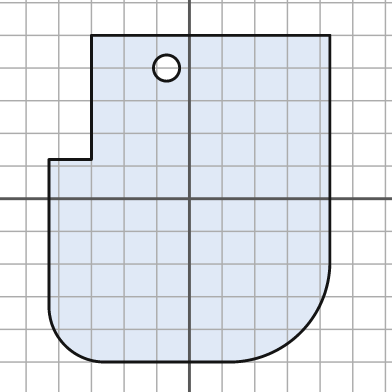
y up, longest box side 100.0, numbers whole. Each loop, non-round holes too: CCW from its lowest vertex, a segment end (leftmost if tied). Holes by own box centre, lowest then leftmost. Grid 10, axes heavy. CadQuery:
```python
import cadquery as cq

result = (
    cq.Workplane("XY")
    .moveTo(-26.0, -50.0)
    .lineTo(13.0, -50.0)
    .threePointArc((34.0, -41.0), (43.0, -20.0))
    .lineTo(43.0, 50.0)
    .lineTo(-30.0, 50.0)
    .lineTo(-30.0, 12.0)
    .lineTo(-43.0, 12.0)
    .lineTo(-43.0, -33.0)
    .threePointArc((-38.0, -45.0), (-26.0, -50.0))
    .close()
    .moveTo(-7.0, 40.0)
    .circle(4.0)
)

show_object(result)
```